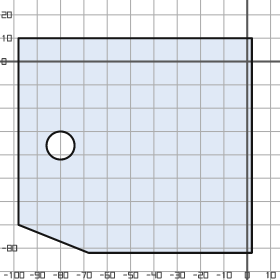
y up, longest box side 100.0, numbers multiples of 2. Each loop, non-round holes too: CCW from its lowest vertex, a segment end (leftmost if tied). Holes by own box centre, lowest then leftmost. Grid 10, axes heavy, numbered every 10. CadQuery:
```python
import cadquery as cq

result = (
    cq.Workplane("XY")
    .moveTo(-68.0, -82.0)
    .lineTo(2.0, -82.0)
    .lineTo(2.0, 10.0)
    .lineTo(-98.0, 10.0)
    .lineTo(-98.0, -70.0)
    .close()
    .moveTo(-80.0, -36.0)
    .circle(6.0)
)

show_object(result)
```